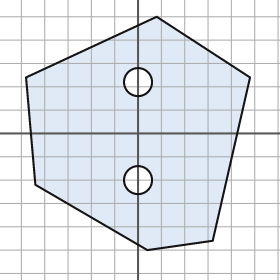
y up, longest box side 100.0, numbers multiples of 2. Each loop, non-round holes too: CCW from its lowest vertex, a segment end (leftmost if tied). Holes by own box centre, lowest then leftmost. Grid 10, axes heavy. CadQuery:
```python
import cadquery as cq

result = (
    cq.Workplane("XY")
    .moveTo(4.0, -50.0)
    .lineTo(32.0, -46.0)
    .lineTo(48.0, 24.0)
    .lineTo(8.0, 50.0)
    .lineTo(-48.0, 24.0)
    .lineTo(-44.0, -22.0)
    .close()
    .moveTo(0.0, -20.0)
    .circle(6.0)
    .moveTo(0.0, 22.0)
    .circle(6.0)
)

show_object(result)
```